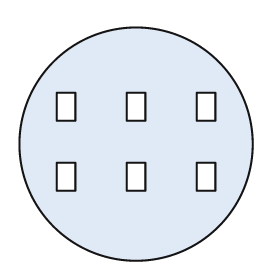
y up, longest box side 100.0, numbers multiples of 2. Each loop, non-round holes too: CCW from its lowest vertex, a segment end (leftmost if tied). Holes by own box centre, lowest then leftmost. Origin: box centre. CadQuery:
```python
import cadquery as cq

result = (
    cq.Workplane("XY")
    .moveTo(0.0, 0.0)
    .circle(50.0)
    .moveTo(-34.0, -20.0)
    .lineTo(-26.0, -20.0)
    .lineTo(-26.0, -8.0)
    .lineTo(-34.0, -8.0)
    .close()
    .moveTo(-4.0, -20.0)
    .lineTo(4.0, -20.0)
    .lineTo(4.0, -8.0)
    .lineTo(-4.0, -8.0)
    .close()
    .moveTo(26.0, -20.0)
    .lineTo(34.0, -20.0)
    .lineTo(34.0, -8.0)
    .lineTo(26.0, -8.0)
    .close()
    .moveTo(-34.0, 10.0)
    .lineTo(-26.0, 10.0)
    .lineTo(-26.0, 22.0)
    .lineTo(-34.0, 22.0)
    .close()
    .moveTo(-4.0, 10.0)
    .lineTo(4.0, 10.0)
    .lineTo(4.0, 22.0)
    .lineTo(-4.0, 22.0)
    .close()
    .moveTo(26.0, 10.0)
    .lineTo(34.0, 10.0)
    .lineTo(34.0, 22.0)
    .lineTo(26.0, 22.0)
    .close()
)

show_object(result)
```